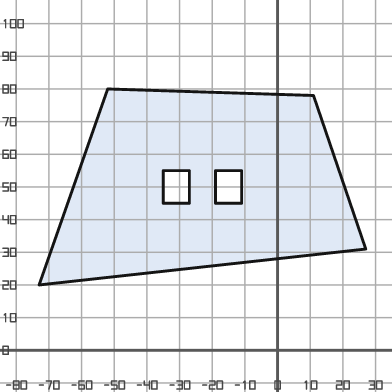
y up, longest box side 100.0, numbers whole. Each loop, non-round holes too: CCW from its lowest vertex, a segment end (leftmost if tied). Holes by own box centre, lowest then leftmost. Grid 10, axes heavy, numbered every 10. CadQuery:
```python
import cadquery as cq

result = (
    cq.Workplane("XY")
    .moveTo(-73.0, 20.0)
    .lineTo(27.0, 31.0)
    .lineTo(11.0, 78.0)
    .lineTo(-52.0, 80.0)
    .close()
    .moveTo(-35.0, 45.0)
    .lineTo(-27.0, 45.0)
    .lineTo(-27.0, 55.0)
    .lineTo(-35.0, 55.0)
    .close()
    .moveTo(-19.0, 45.0)
    .lineTo(-11.0, 45.0)
    .lineTo(-11.0, 55.0)
    .lineTo(-19.0, 55.0)
    .close()
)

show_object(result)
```